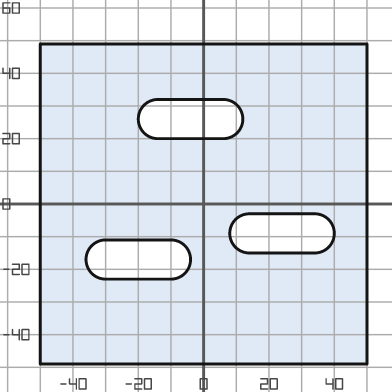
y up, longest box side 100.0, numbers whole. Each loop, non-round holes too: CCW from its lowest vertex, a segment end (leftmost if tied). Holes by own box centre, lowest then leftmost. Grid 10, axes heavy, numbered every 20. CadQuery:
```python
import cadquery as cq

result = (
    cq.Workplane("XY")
    .moveTo(-50.0, -49.0)
    .lineTo(50.0, -49.0)
    .lineTo(50.0, 49.0)
    .lineTo(-50.0, 49.0)
    .close()
    .moveTo(-30.0, -23.0)
    .lineTo(-10.0, -23.0)
    .threePointArc((-4.0, -17.0), (-10.0, -11.0))
    .lineTo(-30.0, -11.0)
    .threePointArc((-36.0, -17.0), (-30.0, -23.0))
    .close()
    .moveTo(14.0, -15.0)
    .lineTo(34.0, -15.0)
    .threePointArc((40.0, -9.0), (34.0, -3.0))
    .lineTo(14.0, -3.0)
    .threePointArc((8.0, -9.0), (14.0, -15.0))
    .close()
    .moveTo(-14.0, 20.0)
    .lineTo(6.0, 20.0)
    .threePointArc((12.0, 26.0), (6.0, 32.0))
    .lineTo(-14.0, 32.0)
    .threePointArc((-20.0, 26.0), (-14.0, 20.0))
    .close()
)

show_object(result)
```